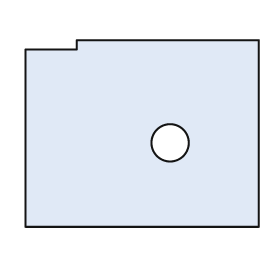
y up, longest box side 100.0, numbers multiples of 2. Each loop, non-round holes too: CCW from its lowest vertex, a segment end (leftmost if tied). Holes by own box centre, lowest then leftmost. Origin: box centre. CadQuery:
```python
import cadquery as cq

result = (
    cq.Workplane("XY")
    .moveTo(-50.0, -40.0)
    .lineTo(50.0, -40.0)
    .lineTo(50.0, 40.0)
    .lineTo(-28.0, 40.0)
    .lineTo(-28.0, 36.0)
    .lineTo(-50.0, 36.0)
    .close()
    .moveTo(12.0, -4.0)
    .circle(8.0)
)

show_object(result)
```